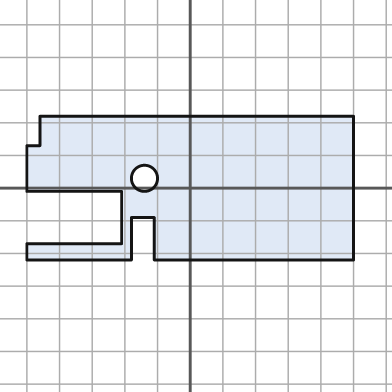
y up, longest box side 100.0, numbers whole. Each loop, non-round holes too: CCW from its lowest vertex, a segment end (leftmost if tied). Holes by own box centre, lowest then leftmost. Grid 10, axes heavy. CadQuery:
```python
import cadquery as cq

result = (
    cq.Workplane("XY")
    .moveTo(-50.0, -22.0)
    .lineTo(-18.0, -22.0)
    .lineTo(-18.0, -9.0)
    .lineTo(-11.0, -9.0)
    .lineTo(-11.0, -22.0)
    .lineTo(50.0, -22.0)
    .lineTo(50.0, 22.0)
    .lineTo(-46.0, 22.0)
    .lineTo(-46.0, 13.0)
    .lineTo(-50.0, 13.0)
    .lineTo(-50.0, -1.0)
    .lineTo(-21.0, -1.0)
    .lineTo(-21.0, -17.0)
    .lineTo(-50.0, -17.0)
    .close()
    .moveTo(-14.0, 3.0)
    .circle(4.0)
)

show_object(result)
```